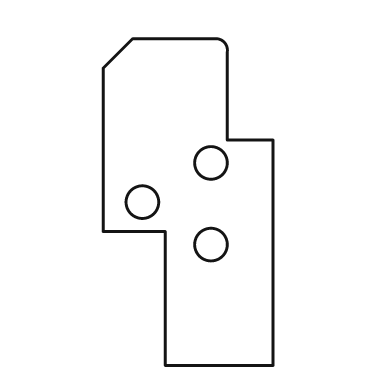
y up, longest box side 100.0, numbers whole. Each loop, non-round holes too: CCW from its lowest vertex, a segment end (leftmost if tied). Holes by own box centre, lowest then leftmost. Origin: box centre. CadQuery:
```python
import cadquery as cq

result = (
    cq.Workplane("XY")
    .moveTo(-7.0, -50.0)
    .lineTo(26.0, -50.0)
    .lineTo(26.0, 19.0)
    .lineTo(12.0, 19.0)
    .lineTo(12.0, 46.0)
    .threePointArc((11.0, 49.0), (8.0, 50.0))
    .lineTo(-17.0, 50.0)
    .lineTo(-26.0, 41.0)
    .lineTo(-26.0, -9.0)
    .lineTo(-7.0, -9.0)
    .close()
    .moveTo(7.0, -13.0)
    .circle(5.0)
    .moveTo(-14.0, 0.0)
    .circle(5.0)
    .moveTo(7.0, 12.0)
    .circle(5.0)
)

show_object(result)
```